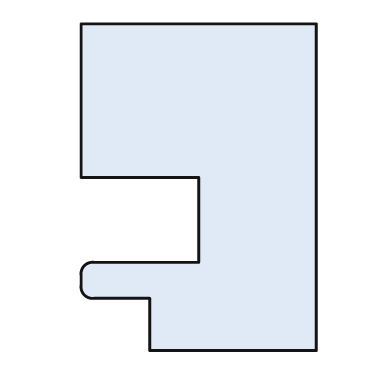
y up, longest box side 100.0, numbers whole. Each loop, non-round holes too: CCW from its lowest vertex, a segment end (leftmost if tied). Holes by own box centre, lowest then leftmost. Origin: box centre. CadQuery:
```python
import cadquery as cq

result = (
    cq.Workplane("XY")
    .moveTo(-15.0, -50.0)
    .lineTo(36.0, -50.0)
    .lineTo(36.0, 50.0)
    .lineTo(-36.0, 50.0)
    .lineTo(-36.0, 3.0)
    .lineTo(0.0, 3.0)
    .lineTo(0.0, -23.0)
    .lineTo(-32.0, -23.0)
    .threePointArc((-35.0, -24.0), (-36.0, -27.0))
    .lineTo(-36.0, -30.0)
    .threePointArc((-35.0, -33.0), (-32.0, -34.0))
    .lineTo(-15.0, -34.0)
    .close()
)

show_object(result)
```